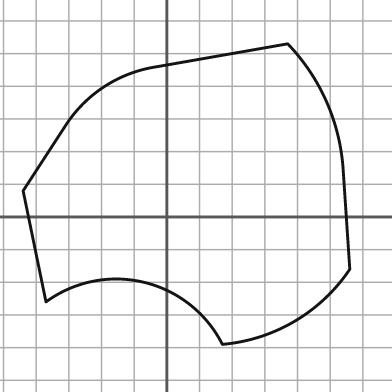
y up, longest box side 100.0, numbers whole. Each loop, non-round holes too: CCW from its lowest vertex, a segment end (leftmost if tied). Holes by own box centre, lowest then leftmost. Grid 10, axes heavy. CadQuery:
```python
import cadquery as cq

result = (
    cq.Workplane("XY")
    .moveTo(17.0, -39.0)
    .threePointArc((39.0, -32.0), (56.0, -16.0))
    .lineTo(54.0, 14.0)
    .threePointArc((49.0, 35.0), (37.0, 53.0))
    .lineTo(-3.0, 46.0)
    .threePointArc((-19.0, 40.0), (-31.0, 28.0))
    .lineTo(-44.0, 8.0)
    .lineTo(-37.0, -26.0)
    .threePointArc((-7.0, -20.0), (17.0, -39.0))
    .close()
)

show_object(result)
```